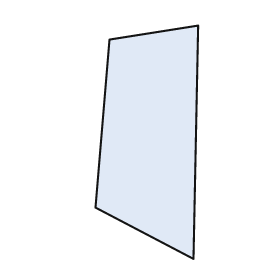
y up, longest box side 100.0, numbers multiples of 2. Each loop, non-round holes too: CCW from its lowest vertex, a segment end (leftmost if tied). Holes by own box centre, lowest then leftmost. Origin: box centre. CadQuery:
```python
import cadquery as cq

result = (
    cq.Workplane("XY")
    .moveTo(20.0, -50.0)
    .lineTo(22.0, 50.0)
    .lineTo(-16.0, 44.0)
    .lineTo(-22.0, -28.0)
    .close()
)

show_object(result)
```